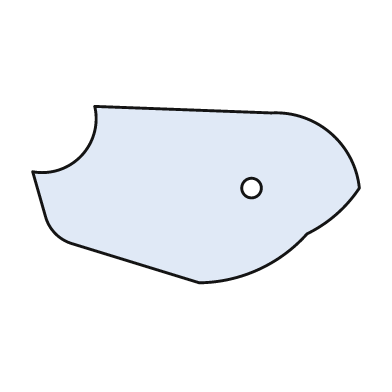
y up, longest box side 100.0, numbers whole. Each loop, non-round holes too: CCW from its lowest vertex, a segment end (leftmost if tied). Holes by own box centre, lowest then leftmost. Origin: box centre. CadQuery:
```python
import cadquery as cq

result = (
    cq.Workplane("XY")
    .moveTo(1.0, -27.0)
    .threePointArc((19.0, -23.0), (34.0, -12.0))
    .threePointArc((43.0, -6.0), (50.0, 2.0))
    .threePointArc((41.0, 19.0), (23.0, 25.0))
    .lineTo(-31.0, 27.0)
    .threePointArc((-35.0, 12.0), (-50.0, 7.0))
    .lineTo(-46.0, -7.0)
    .threePointArc((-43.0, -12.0), (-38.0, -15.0))
    .close()
    .moveTo(17.0, 2.0)
    .circle(3.0)
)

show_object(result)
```